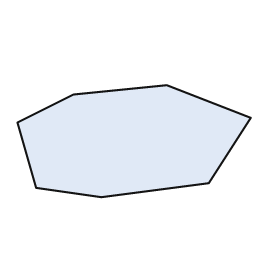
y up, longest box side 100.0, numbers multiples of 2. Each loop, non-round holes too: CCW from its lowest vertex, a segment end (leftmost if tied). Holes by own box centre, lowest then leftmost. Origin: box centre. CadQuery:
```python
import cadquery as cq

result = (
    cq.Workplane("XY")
    .moveTo(-14.0, -24.0)
    .lineTo(32.0, -18.0)
    .lineTo(50.0, 10.0)
    .lineTo(14.0, 24.0)
    .lineTo(-26.0, 20.0)
    .lineTo(-50.0, 8.0)
    .lineTo(-42.0, -20.0)
    .close()
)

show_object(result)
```